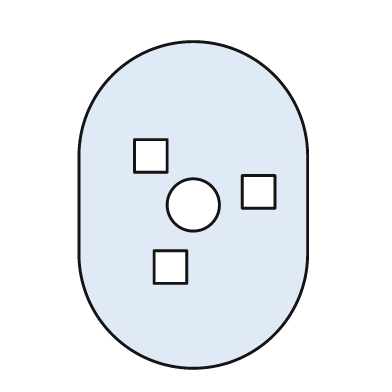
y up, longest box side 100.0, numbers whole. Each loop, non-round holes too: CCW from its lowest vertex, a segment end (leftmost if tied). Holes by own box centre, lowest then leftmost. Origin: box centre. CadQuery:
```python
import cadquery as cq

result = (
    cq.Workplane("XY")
    .moveTo(-35.0, -15.0)
    .threePointArc((0.0, -50.0), (35.0, -15.0))
    .lineTo(35.0, 15.0)
    .threePointArc((0.0, 50.0), (-35.0, 15.0))
    .close()
    .moveTo(-12.0, -24.0)
    .lineTo(-2.0, -24.0)
    .lineTo(-2.0, -14.0)
    .lineTo(-12.0, -14.0)
    .close()
    .moveTo(0.0, 0.0)
    .circle(8.0)
    .moveTo(15.0, -1.0)
    .lineTo(25.0, -1.0)
    .lineTo(25.0, 9.0)
    .lineTo(15.0, 9.0)
    .close()
    .moveTo(-18.0, 10.0)
    .lineTo(-8.0, 10.0)
    .lineTo(-8.0, 20.0)
    .lineTo(-18.0, 20.0)
    .close()
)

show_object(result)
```